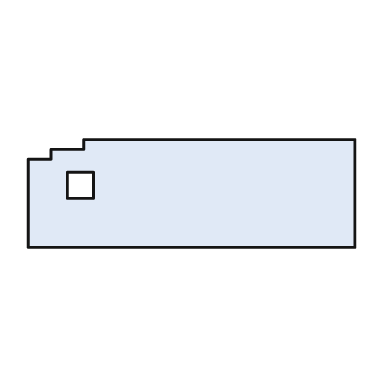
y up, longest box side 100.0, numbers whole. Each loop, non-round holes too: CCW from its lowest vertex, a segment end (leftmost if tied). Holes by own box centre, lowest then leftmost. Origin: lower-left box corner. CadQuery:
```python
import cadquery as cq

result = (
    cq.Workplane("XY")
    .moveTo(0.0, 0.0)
    .lineTo(100.0, 0.0)
    .lineTo(100.0, 33.0)
    .lineTo(17.0, 33.0)
    .lineTo(17.0, 30.0)
    .lineTo(7.0, 30.0)
    .lineTo(7.0, 27.0)
    .lineTo(0.0, 27.0)
    .close()
    .moveTo(12.0, 15.0)
    .lineTo(20.0, 15.0)
    .lineTo(20.0, 23.0)
    .lineTo(12.0, 23.0)
    .close()
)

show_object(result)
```